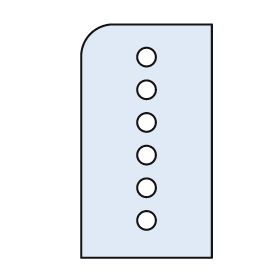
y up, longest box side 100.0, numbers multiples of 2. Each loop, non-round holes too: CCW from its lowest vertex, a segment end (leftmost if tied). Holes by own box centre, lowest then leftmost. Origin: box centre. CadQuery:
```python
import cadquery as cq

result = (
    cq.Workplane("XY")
    .moveTo(-28.0, -50.0)
    .lineTo(28.0, -50.0)
    .lineTo(28.0, 50.0)
    .lineTo(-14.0, 50.0)
    .threePointArc((-24.0, 46.0), (-28.0, 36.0))
    .close()
    .moveTo(0.0, -34.0)
    .circle(4.0)
    .moveTo(0.0, -20.0)
    .circle(4.0)
    .moveTo(0.0, -6.0)
    .circle(4.0)
    .moveTo(0.0, 8.0)
    .circle(4.0)
    .moveTo(0.0, 22.0)
    .circle(4.0)
    .moveTo(0.0, 36.0)
    .circle(4.0)
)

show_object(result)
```